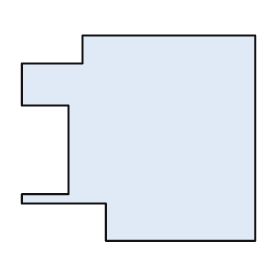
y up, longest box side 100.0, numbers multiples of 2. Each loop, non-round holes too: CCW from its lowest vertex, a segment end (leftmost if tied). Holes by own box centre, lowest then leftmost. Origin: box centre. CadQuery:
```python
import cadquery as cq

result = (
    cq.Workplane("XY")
    .moveTo(-14.0, -44.0)
    .lineTo(50.0, -44.0)
    .lineTo(50.0, 44.0)
    .lineTo(-24.0, 44.0)
    .lineTo(-24.0, 32.0)
    .lineTo(-50.0, 32.0)
    .lineTo(-50.0, 14.0)
    .lineTo(-30.0, 14.0)
    .lineTo(-30.0, -24.0)
    .lineTo(-50.0, -24.0)
    .lineTo(-50.0, -28.0)
    .lineTo(-14.0, -28.0)
    .close()
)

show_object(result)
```